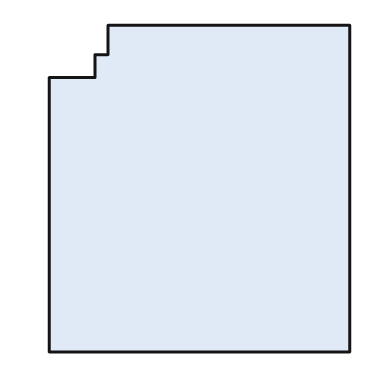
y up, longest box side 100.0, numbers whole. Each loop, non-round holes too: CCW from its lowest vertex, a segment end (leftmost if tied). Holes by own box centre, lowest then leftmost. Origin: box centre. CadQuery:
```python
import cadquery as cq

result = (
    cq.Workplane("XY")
    .moveTo(-46.0, -50.0)
    .lineTo(46.0, -50.0)
    .lineTo(46.0, 50.0)
    .lineTo(-28.0, 50.0)
    .lineTo(-28.0, 41.0)
    .lineTo(-32.0, 41.0)
    .lineTo(-32.0, 34.0)
    .lineTo(-46.0, 34.0)
    .close()
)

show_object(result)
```